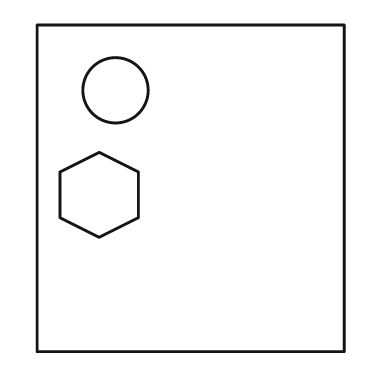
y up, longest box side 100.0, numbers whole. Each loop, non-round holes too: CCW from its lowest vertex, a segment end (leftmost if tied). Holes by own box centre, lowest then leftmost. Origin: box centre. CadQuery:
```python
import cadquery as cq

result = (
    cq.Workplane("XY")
    .moveTo(-47.0, -50.0)
    .lineTo(47.0, -50.0)
    .lineTo(47.0, 50.0)
    .lineTo(-47.0, 50.0)
    .close()
    .moveTo(-28.0, -15.0)
    .lineTo(-16.0, -9.0)
    .lineTo(-16.0, 5.0)
    .lineTo(-28.0, 11.0)
    .lineTo(-40.0, 5.0)
    .lineTo(-40.0, -9.0)
    .close()
    .moveTo(-23.0, 30.0)
    .circle(10.0)
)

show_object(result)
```